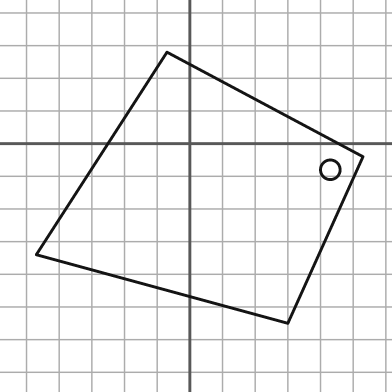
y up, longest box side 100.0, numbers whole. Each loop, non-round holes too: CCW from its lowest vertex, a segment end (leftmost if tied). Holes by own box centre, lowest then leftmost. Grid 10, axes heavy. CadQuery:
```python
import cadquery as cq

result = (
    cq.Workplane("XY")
    .moveTo(30.0, -55.0)
    .lineTo(53.0, -4.0)
    .lineTo(-7.0, 28.0)
    .lineTo(-47.0, -34.0)
    .close()
    .moveTo(43.0, -8.0)
    .circle(3.0)
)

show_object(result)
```